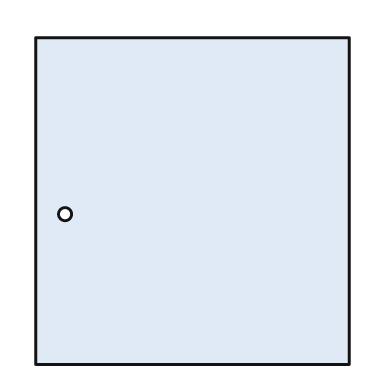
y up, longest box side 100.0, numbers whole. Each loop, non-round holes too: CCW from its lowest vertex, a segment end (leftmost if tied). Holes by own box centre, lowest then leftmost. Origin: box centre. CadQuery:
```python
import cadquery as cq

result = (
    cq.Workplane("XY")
    .moveTo(-48.0, -50.0)
    .lineTo(48.0, -50.0)
    .lineTo(48.0, 50.0)
    .lineTo(-48.0, 50.0)
    .close()
    .moveTo(-39.0, -4.0)
    .circle(2.0)
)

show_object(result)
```